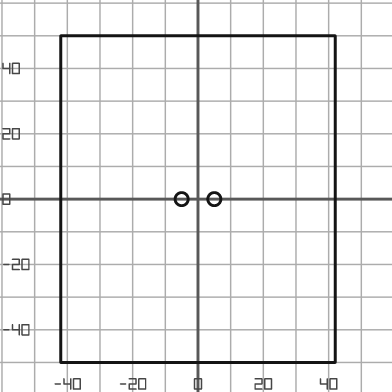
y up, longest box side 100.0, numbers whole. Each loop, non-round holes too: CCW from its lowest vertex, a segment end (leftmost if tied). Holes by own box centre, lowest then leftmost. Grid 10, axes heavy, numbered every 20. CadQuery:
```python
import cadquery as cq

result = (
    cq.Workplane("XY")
    .moveTo(-42.0, -50.0)
    .lineTo(42.0, -50.0)
    .lineTo(42.0, 50.0)
    .lineTo(-42.0, 50.0)
    .close()
    .moveTo(-5.0, 0.0)
    .circle(2.0)
    .moveTo(5.0, 0.0)
    .circle(2.0)
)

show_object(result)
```